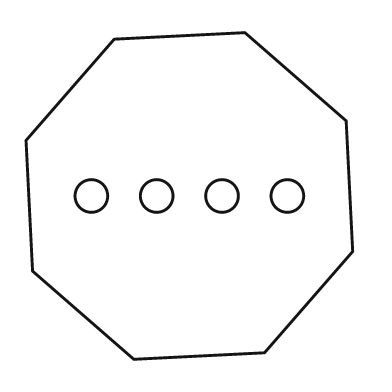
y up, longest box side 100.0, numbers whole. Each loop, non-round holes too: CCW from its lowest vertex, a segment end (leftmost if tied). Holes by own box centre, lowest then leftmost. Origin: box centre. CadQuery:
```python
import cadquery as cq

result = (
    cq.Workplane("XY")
    .moveTo(-17.0, -50.0)
    .lineTo(23.0, -48.0)
    .lineTo(50.0, -17.0)
    .lineTo(48.0, 23.0)
    .lineTo(17.0, 50.0)
    .lineTo(-23.0, 48.0)
    .lineTo(-50.0, 17.0)
    .lineTo(-48.0, -23.0)
    .close()
    .moveTo(-30.0, 0.0)
    .circle(5.0)
    .moveTo(-10.0, 0.0)
    .circle(5.0)
    .moveTo(10.0, 0.0)
    .circle(5.0)
    .moveTo(30.0, 0.0)
    .circle(5.0)
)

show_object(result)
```